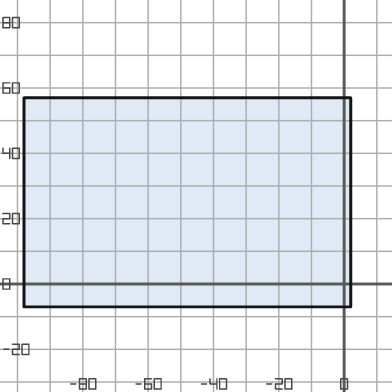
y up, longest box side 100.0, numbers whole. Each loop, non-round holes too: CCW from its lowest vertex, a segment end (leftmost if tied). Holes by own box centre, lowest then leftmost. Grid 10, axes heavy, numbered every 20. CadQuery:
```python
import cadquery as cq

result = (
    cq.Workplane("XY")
    .moveTo(-98.0, -7.0)
    .lineTo(2.0, -7.0)
    .lineTo(2.0, 57.0)
    .lineTo(-98.0, 57.0)
    .close()
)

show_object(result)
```